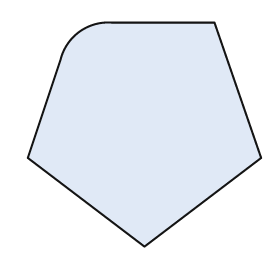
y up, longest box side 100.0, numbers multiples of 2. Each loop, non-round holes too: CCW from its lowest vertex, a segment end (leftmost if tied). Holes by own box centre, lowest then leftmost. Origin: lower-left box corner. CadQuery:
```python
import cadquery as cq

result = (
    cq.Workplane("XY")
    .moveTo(50.0, 0.0)
    .lineTo(100.0, 38.0)
    .lineTo(80.0, 96.0)
    .lineTo(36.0, 96.0)
    .threePointArc((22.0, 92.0), (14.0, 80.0))
    .lineTo(0.0, 38.0)
    .close()
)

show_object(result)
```